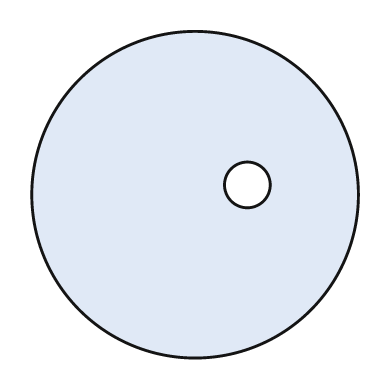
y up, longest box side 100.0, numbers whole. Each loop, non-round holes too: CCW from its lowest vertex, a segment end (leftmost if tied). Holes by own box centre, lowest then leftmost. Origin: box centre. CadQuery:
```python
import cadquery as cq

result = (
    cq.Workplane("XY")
    .moveTo(0.0, 0.0)
    .circle(50.0)
    .moveTo(16.0, 3.0)
    .circle(7.0)
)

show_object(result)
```